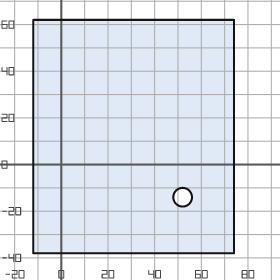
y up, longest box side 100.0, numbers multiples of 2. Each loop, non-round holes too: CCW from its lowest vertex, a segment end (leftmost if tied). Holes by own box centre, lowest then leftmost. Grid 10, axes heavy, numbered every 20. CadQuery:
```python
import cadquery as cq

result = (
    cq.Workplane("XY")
    .moveTo(-12.0, -38.0)
    .lineTo(74.0, -38.0)
    .lineTo(74.0, 62.0)
    .lineTo(-12.0, 62.0)
    .close()
    .moveTo(52.0, -14.0)
    .circle(4.0)
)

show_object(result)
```